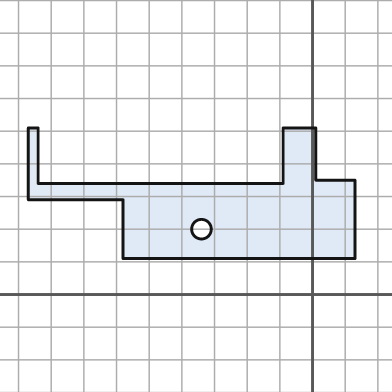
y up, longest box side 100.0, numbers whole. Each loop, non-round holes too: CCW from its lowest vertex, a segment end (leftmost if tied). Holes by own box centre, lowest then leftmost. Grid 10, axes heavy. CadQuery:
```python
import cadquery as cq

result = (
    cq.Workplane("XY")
    .moveTo(-58.0, 11.0)
    .lineTo(13.0, 11.0)
    .lineTo(13.0, 35.0)
    .lineTo(1.0, 35.0)
    .lineTo(1.0, 51.0)
    .lineTo(-9.0, 51.0)
    .lineTo(-9.0, 34.0)
    .lineTo(-84.0, 34.0)
    .lineTo(-84.0, 51.0)
    .lineTo(-87.0, 51.0)
    .lineTo(-87.0, 29.0)
    .lineTo(-58.0, 29.0)
    .close()
    .moveTo(-34.0, 20.0)
    .circle(3.0)
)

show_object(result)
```